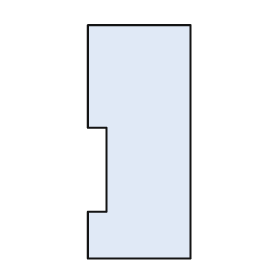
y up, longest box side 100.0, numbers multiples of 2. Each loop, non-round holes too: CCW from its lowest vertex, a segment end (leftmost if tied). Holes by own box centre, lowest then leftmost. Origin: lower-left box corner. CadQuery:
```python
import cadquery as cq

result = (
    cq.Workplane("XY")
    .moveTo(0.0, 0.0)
    .lineTo(44.0, 0.0)
    .lineTo(44.0, 100.0)
    .lineTo(0.0, 100.0)
    .lineTo(0.0, 56.0)
    .lineTo(8.0, 56.0)
    .lineTo(8.0, 20.0)
    .lineTo(0.0, 20.0)
    .close()
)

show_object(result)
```